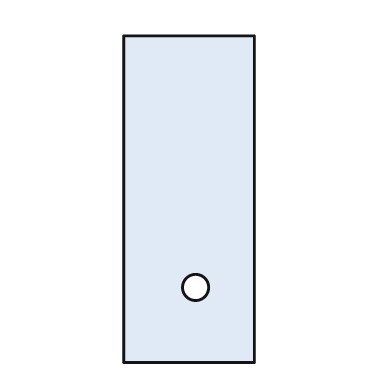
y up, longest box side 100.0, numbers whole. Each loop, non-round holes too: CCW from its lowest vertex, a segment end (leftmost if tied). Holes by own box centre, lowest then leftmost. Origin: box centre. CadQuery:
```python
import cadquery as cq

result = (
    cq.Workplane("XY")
    .moveTo(-20.0, -50.0)
    .lineTo(20.0, -50.0)
    .lineTo(20.0, 50.0)
    .lineTo(-20.0, 50.0)
    .close()
    .moveTo(2.0, -27.0)
    .circle(4.0)
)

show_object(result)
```